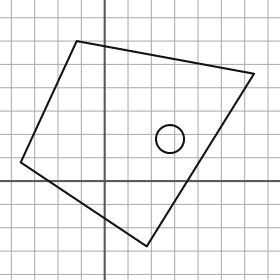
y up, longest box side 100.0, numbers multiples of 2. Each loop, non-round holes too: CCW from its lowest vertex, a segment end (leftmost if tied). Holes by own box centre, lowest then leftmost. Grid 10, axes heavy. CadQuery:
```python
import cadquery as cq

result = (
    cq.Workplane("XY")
    .moveTo(18.0, -28.0)
    .lineTo(64.0, 46.0)
    .lineTo(-12.0, 60.0)
    .lineTo(-36.0, 8.0)
    .close()
    .moveTo(28.0, 18.0)
    .circle(6.0)
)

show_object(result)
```